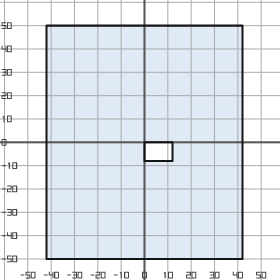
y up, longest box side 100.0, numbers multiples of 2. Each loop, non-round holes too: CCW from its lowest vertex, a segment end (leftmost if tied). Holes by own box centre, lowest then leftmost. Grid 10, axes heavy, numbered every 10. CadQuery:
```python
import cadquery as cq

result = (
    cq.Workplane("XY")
    .moveTo(-42.0, -50.0)
    .lineTo(42.0, -50.0)
    .lineTo(42.0, 50.0)
    .lineTo(-42.0, 50.0)
    .close()
    .moveTo(0.0, -8.0)
    .lineTo(12.0, -8.0)
    .lineTo(12.0, 0.0)
    .lineTo(0.0, 0.0)
    .close()
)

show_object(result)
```